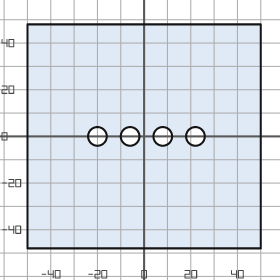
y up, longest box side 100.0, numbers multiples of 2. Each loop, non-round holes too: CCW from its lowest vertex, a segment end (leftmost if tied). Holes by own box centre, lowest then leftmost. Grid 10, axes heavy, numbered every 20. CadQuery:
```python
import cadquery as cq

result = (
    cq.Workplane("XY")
    .moveTo(-50.0, -48.0)
    .lineTo(50.0, -48.0)
    .lineTo(50.0, 48.0)
    .lineTo(-50.0, 48.0)
    .close()
    .moveTo(-20.0, 0.0)
    .circle(4.0)
    .moveTo(-6.0, 0.0)
    .circle(4.0)
    .moveTo(8.0, 0.0)
    .circle(4.0)
    .moveTo(22.0, 0.0)
    .circle(4.0)
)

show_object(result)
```